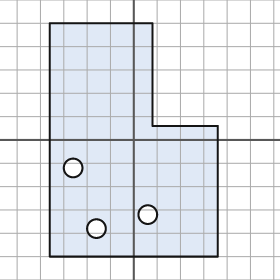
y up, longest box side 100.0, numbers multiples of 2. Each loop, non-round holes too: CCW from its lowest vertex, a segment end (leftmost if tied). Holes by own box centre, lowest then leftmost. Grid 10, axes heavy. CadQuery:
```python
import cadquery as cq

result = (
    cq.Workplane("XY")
    .moveTo(-36.0, -50.0)
    .lineTo(36.0, -50.0)
    .lineTo(36.0, 6.0)
    .lineTo(8.0, 6.0)
    .lineTo(8.0, 50.0)
    .lineTo(-36.0, 50.0)
    .close()
    .moveTo(-16.0, -38.0)
    .circle(4.0)
    .moveTo(6.0, -32.0)
    .circle(4.0)
    .moveTo(-26.0, -12.0)
    .circle(4.0)
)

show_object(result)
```